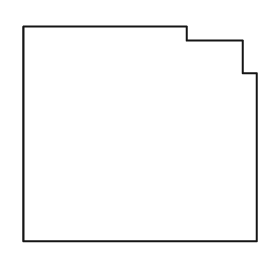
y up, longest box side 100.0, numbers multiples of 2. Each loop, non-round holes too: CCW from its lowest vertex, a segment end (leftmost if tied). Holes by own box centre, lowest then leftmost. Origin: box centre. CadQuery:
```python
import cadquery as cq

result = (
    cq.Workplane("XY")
    .moveTo(-50.0, -46.0)
    .lineTo(50.0, -46.0)
    .lineTo(50.0, 26.0)
    .lineTo(44.0, 26.0)
    .lineTo(44.0, 40.0)
    .lineTo(20.0, 40.0)
    .lineTo(20.0, 46.0)
    .lineTo(-50.0, 46.0)
    .close()
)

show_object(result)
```